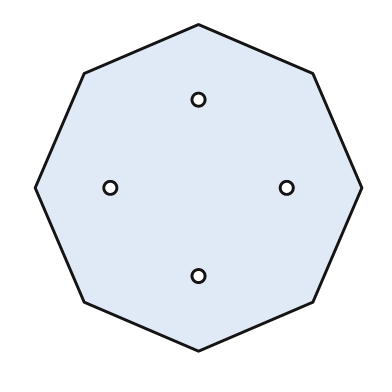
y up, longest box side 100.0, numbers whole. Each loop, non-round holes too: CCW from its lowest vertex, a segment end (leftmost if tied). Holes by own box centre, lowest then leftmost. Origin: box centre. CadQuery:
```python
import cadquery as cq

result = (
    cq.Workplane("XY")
    .moveTo(0.0, -50.0)
    .lineTo(35.0, -35.0)
    .lineTo(50.0, 0.0)
    .lineTo(35.0, 35.0)
    .lineTo(0.0, 50.0)
    .lineTo(-35.0, 35.0)
    .lineTo(-50.0, 0.0)
    .lineTo(-35.0, -35.0)
    .close()
    .moveTo(0.0, -27.0)
    .circle(2.0)
    .moveTo(-27.0, 0.0)
    .circle(2.0)
    .moveTo(27.0, 0.0)
    .circle(2.0)
    .moveTo(0.0, 27.0)
    .circle(2.0)
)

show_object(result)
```